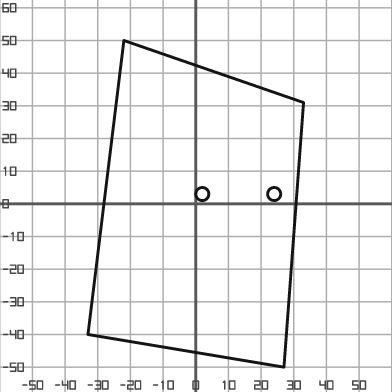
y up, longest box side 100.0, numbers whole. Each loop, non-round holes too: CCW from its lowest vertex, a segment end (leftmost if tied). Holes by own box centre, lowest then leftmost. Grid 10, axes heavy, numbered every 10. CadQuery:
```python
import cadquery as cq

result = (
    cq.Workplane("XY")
    .moveTo(27.0, -50.0)
    .lineTo(33.0, 31.0)
    .lineTo(-22.0, 50.0)
    .lineTo(-33.0, -40.0)
    .close()
    .moveTo(2.0, 3.0)
    .circle(2.0)
    .moveTo(24.0, 3.0)
    .circle(2.0)
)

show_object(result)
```